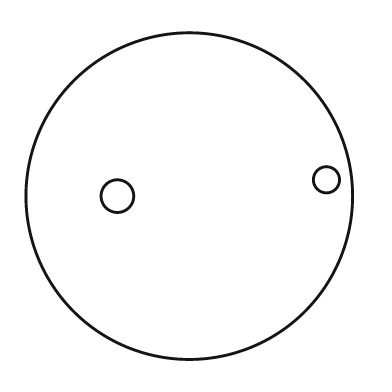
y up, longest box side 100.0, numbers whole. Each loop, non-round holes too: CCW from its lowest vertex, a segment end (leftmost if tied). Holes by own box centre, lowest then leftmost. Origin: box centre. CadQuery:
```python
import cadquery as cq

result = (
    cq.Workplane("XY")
    .moveTo(0.0, 0.0)
    .circle(50.0)
    .moveTo(-22.0, 0.0)
    .circle(5.0)
    .moveTo(42.0, 5.0)
    .circle(4.0)
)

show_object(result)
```